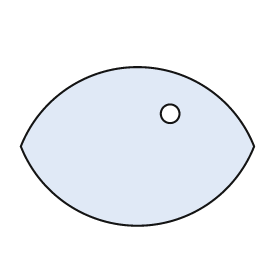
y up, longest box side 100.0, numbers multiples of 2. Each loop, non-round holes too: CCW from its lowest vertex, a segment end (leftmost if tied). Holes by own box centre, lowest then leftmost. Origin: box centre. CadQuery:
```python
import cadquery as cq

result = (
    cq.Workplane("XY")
    .moveTo(-50.0, 0.0)
    .threePointArc((0.0, -34.0), (50.0, 0.0))
    .threePointArc((0.0, 34.0), (-50.0, 0.0))
    .close()
    .moveTo(14.0, 14.0)
    .circle(4.0)
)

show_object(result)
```